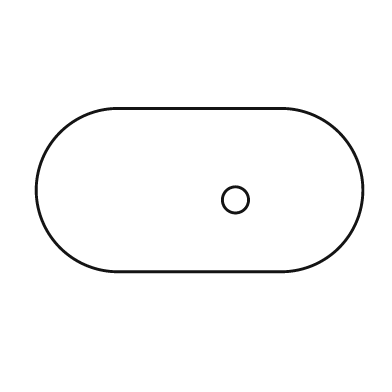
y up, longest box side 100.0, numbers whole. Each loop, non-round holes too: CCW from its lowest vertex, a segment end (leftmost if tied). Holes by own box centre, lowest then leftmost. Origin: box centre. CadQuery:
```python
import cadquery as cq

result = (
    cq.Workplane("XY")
    .moveTo(-25.0, -25.0)
    .lineTo(25.0, -25.0)
    .threePointArc((50.0, 0.0), (25.0, 25.0))
    .lineTo(-25.0, 25.0)
    .threePointArc((-50.0, 0.0), (-25.0, -25.0))
    .close()
    .moveTo(11.0, -3.0)
    .circle(4.0)
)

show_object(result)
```